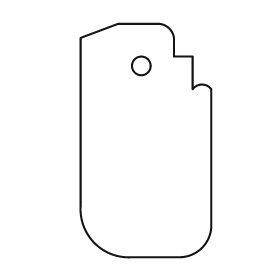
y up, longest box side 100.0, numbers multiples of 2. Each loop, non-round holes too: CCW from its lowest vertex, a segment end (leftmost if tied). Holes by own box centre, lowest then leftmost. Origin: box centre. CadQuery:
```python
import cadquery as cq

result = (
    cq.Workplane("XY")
    .moveTo(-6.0, -50.0)
    .lineTo(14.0, -50.0)
    .threePointArc((24.0, -46.0), (28.0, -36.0))
    .lineTo(28.0, 22.0)
    .threePointArc((24.0, 24.0), (20.0, 22.0))
    .lineTo(20.0, 36.0)
    .lineTo(12.0, 36.0)
    .lineTo(12.0, 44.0)
    .threePointArc((10.0, 48.0), (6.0, 50.0))
    .lineTo(-12.0, 50.0)
    .lineTo(-28.0, 44.0)
    .lineTo(-28.0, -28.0)
    .threePointArc((-22.0, -44.0), (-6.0, -50.0))
    .close()
    .moveTo(-2.0, 32.0)
    .circle(4.0)
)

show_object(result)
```